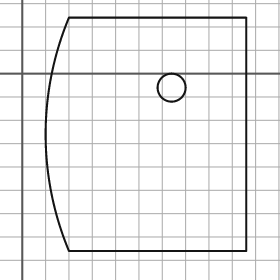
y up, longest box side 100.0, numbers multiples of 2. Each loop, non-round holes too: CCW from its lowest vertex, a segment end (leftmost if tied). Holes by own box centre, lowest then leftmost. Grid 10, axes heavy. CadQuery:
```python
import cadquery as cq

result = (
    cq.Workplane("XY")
    .moveTo(20.0, -76.0)
    .lineTo(96.0, -76.0)
    .lineTo(96.0, 24.0)
    .lineTo(20.0, 24.0)
    .threePointArc((10.0, -26.0), (20.0, -76.0))
    .close()
    .moveTo(64.0, -6.0)
    .circle(6.0)
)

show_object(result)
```